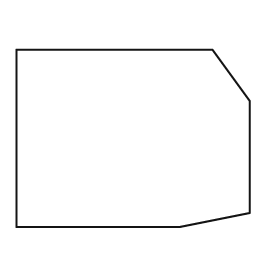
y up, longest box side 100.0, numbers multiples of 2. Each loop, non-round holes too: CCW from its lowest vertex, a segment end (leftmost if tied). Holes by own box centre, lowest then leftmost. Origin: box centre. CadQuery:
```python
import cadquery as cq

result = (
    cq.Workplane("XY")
    .moveTo(-50.0, -38.0)
    .lineTo(20.0, -38.0)
    .lineTo(50.0, -32.0)
    .lineTo(50.0, 16.0)
    .lineTo(34.0, 38.0)
    .lineTo(-50.0, 38.0)
    .close()
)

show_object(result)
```